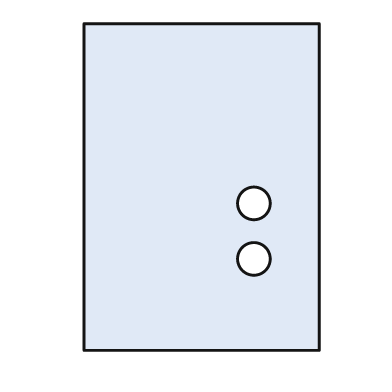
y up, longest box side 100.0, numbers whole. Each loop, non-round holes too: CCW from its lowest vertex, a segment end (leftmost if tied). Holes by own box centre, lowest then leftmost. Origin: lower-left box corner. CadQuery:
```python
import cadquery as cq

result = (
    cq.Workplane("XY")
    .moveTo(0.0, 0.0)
    .lineTo(72.0, 0.0)
    .lineTo(72.0, 100.0)
    .lineTo(0.0, 100.0)
    .close()
    .moveTo(52.0, 28.0)
    .circle(5.0)
    .moveTo(52.0, 45.0)
    .circle(5.0)
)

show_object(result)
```